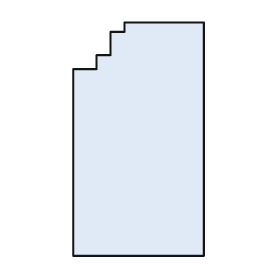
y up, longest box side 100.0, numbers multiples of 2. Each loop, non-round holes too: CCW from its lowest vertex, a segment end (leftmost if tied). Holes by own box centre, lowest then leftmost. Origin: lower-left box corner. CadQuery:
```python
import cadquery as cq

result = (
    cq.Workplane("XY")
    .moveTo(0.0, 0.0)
    .lineTo(56.0, 0.0)
    .lineTo(56.0, 100.0)
    .lineTo(22.0, 100.0)
    .lineTo(22.0, 96.0)
    .lineTo(16.0, 96.0)
    .lineTo(16.0, 86.0)
    .lineTo(10.0, 86.0)
    .lineTo(10.0, 80.0)
    .lineTo(0.0, 80.0)
    .close()
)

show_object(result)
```